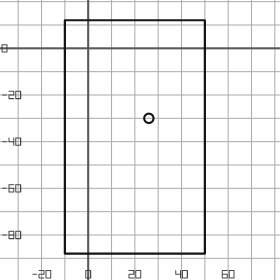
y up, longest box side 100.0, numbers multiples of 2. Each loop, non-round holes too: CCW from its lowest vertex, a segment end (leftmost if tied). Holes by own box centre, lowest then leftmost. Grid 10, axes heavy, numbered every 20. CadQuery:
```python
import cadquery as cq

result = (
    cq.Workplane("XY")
    .moveTo(-10.0, -88.0)
    .lineTo(50.0, -88.0)
    .lineTo(50.0, 12.0)
    .lineTo(-10.0, 12.0)
    .close()
    .moveTo(26.0, -30.0)
    .circle(2.0)
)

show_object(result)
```